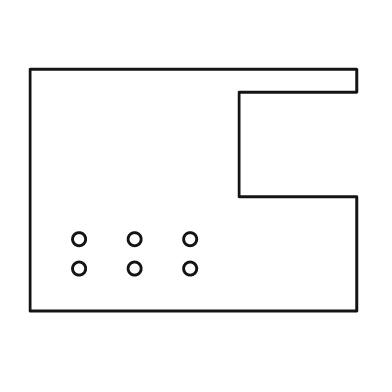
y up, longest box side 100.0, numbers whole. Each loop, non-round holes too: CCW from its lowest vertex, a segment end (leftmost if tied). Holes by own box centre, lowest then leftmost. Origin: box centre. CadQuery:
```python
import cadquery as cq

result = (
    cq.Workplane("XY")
    .moveTo(-50.0, -37.0)
    .lineTo(50.0, -37.0)
    .lineTo(50.0, -2.0)
    .lineTo(14.0, -2.0)
    .lineTo(14.0, 30.0)
    .lineTo(50.0, 30.0)
    .lineTo(50.0, 37.0)
    .lineTo(-50.0, 37.0)
    .close()
    .moveTo(-35.0, -24.0)
    .circle(2.0)
    .moveTo(-18.0, -24.0)
    .circle(2.0)
    .moveTo(-1.0, -24.0)
    .circle(2.0)
    .moveTo(-35.0, -15.0)
    .circle(2.0)
    .moveTo(-18.0, -15.0)
    .circle(2.0)
    .moveTo(-1.0, -15.0)
    .circle(2.0)
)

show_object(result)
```